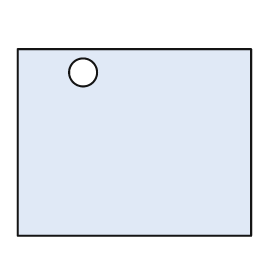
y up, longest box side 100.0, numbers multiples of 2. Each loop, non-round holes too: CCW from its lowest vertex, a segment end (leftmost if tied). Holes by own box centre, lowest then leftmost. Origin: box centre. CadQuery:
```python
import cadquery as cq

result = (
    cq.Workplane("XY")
    .moveTo(-50.0, -40.0)
    .lineTo(50.0, -40.0)
    .lineTo(50.0, 40.0)
    .lineTo(-50.0, 40.0)
    .close()
    .moveTo(-22.0, 30.0)
    .circle(6.0)
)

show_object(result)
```